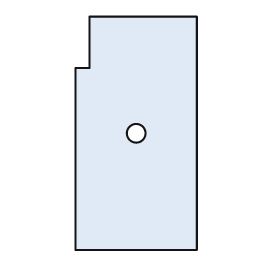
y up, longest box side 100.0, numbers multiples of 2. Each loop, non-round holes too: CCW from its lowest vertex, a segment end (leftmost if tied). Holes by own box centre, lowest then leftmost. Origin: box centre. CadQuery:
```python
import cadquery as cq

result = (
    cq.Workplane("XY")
    .moveTo(-26.0, -50.0)
    .lineTo(26.0, -50.0)
    .lineTo(26.0, 50.0)
    .lineTo(-20.0, 50.0)
    .lineTo(-20.0, 28.0)
    .lineTo(-26.0, 28.0)
    .close()
    .moveTo(0.0, 0.0)
    .circle(4.0)
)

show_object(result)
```